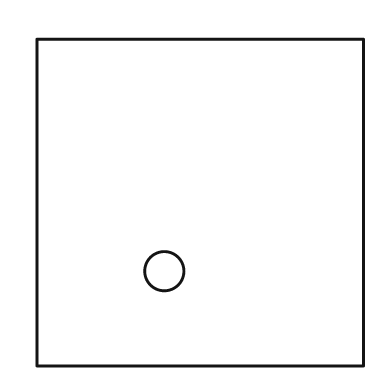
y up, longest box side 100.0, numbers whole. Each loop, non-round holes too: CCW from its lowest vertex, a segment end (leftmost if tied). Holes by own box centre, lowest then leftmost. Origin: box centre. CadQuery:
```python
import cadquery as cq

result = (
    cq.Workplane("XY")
    .moveTo(-50.0, -50.0)
    .lineTo(50.0, -50.0)
    .lineTo(50.0, 50.0)
    .lineTo(-50.0, 50.0)
    .close()
    .moveTo(-11.0, -21.0)
    .circle(6.0)
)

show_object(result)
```